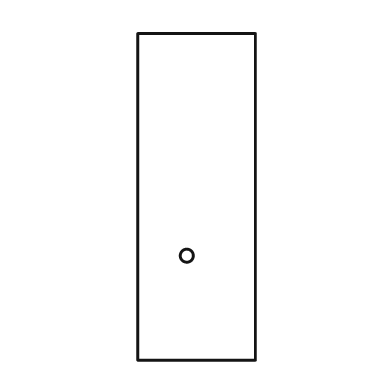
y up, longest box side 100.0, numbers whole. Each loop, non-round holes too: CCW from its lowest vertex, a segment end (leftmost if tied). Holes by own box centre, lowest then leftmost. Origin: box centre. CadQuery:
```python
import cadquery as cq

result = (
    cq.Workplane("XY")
    .moveTo(-18.0, -50.0)
    .lineTo(18.0, -50.0)
    .lineTo(18.0, 50.0)
    .lineTo(-18.0, 50.0)
    .close()
    .moveTo(-3.0, -18.0)
    .circle(2.0)
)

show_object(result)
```